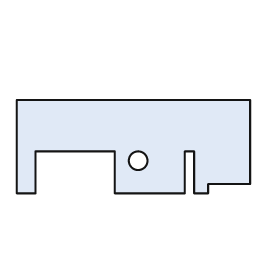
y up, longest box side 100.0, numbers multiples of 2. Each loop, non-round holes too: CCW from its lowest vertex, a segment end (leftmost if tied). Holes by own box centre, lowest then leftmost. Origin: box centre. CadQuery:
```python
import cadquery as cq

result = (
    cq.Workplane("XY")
    .moveTo(-50.0, -20.0)
    .lineTo(-42.0, -20.0)
    .lineTo(-42.0, -2.0)
    .lineTo(-8.0, -2.0)
    .lineTo(-8.0, -20.0)
    .lineTo(22.0, -20.0)
    .lineTo(22.0, -2.0)
    .lineTo(26.0, -2.0)
    .lineTo(26.0, -20.0)
    .lineTo(32.0, -20.0)
    .lineTo(32.0, -16.0)
    .lineTo(50.0, -16.0)
    .lineTo(50.0, 20.0)
    .lineTo(-50.0, 20.0)
    .close()
    .moveTo(2.0, -6.0)
    .circle(4.0)
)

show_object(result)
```